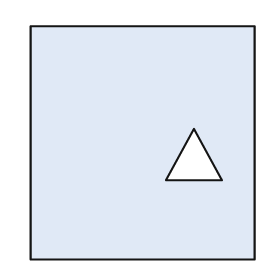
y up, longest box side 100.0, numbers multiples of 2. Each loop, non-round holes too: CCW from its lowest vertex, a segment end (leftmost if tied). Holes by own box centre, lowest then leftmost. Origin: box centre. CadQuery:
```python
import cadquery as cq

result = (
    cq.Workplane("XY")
    .moveTo(-48.0, -50.0)
    .lineTo(48.0, -50.0)
    .lineTo(48.0, 50.0)
    .lineTo(-48.0, 50.0)
    .close()
    .moveTo(10.0, -16.0)
    .lineTo(34.0, -16.0)
    .lineTo(22.0, 6.0)
    .close()
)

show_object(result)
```